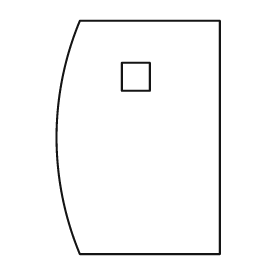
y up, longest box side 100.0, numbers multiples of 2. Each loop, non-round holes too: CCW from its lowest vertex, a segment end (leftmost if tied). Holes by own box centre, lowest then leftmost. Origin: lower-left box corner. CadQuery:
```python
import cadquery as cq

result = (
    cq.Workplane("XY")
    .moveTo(10.0, 0.0)
    .lineTo(70.0, 0.0)
    .lineTo(70.0, 100.0)
    .lineTo(10.0, 100.0)
    .threePointArc((0.0, 50.0), (10.0, 0.0))
    .close()
    .moveTo(28.0, 70.0)
    .lineTo(40.0, 70.0)
    .lineTo(40.0, 82.0)
    .lineTo(28.0, 82.0)
    .close()
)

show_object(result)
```